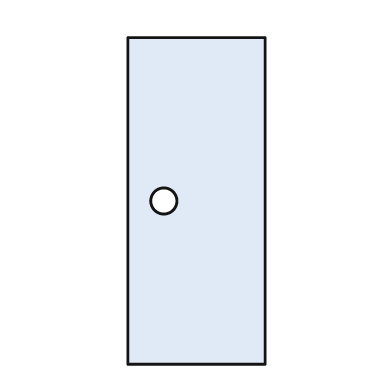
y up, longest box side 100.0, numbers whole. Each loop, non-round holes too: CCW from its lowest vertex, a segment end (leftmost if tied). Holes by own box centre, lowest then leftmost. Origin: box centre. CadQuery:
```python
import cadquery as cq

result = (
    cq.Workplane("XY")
    .moveTo(-21.0, -50.0)
    .lineTo(21.0, -50.0)
    .lineTo(21.0, 50.0)
    .lineTo(-21.0, 50.0)
    .close()
    .moveTo(-10.0, 0.0)
    .circle(4.0)
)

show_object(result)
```